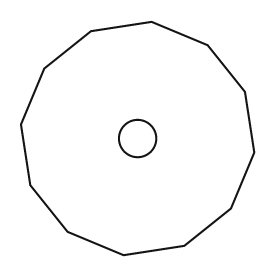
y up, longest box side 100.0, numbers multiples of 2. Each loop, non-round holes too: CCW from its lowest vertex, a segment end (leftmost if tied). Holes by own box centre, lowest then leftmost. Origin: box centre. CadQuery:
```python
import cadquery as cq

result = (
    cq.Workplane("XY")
    .moveTo(-6.0, -50.0)
    .lineTo(20.0, -46.0)
    .lineTo(40.0, -30.0)
    .lineTo(50.0, -6.0)
    .lineTo(46.0, 20.0)
    .lineTo(30.0, 40.0)
    .lineTo(6.0, 50.0)
    .lineTo(-20.0, 46.0)
    .lineTo(-40.0, 30.0)
    .lineTo(-50.0, 6.0)
    .lineTo(-46.0, -20.0)
    .lineTo(-30.0, -40.0)
    .close()
    .moveTo(0.0, 0.0)
    .circle(8.0)
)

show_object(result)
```